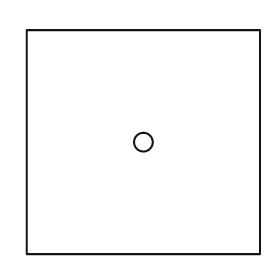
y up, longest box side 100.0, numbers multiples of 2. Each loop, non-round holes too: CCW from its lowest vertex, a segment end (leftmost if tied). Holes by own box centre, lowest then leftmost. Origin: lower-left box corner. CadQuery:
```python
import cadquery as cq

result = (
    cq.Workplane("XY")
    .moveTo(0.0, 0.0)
    .lineTo(100.0, 0.0)
    .lineTo(100.0, 96.0)
    .lineTo(0.0, 96.0)
    .close()
    .moveTo(50.0, 48.0)
    .circle(4.0)
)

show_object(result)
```